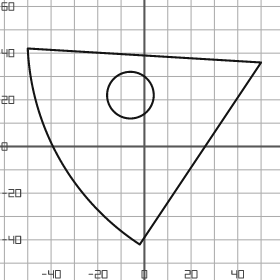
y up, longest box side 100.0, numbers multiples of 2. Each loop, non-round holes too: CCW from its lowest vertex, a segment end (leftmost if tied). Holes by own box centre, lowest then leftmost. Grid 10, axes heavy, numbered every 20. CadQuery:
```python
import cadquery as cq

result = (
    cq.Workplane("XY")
    .moveTo(-2.0, -42.0)
    .lineTo(50.0, 36.0)
    .lineTo(-50.0, 42.0)
    .threePointArc((-36.0, -6.0), (-2.0, -42.0))
    .close()
    .moveTo(-6.0, 22.0)
    .circle(10.0)
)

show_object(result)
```